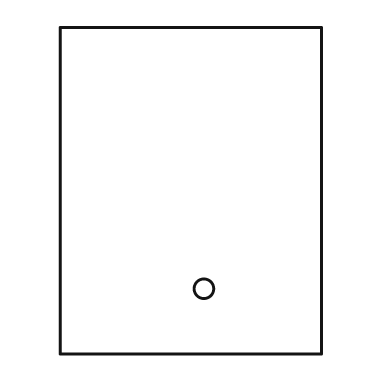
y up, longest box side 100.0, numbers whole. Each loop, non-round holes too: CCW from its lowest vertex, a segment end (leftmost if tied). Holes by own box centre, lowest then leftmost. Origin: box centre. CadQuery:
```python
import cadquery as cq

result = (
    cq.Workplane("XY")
    .moveTo(-40.0, -50.0)
    .lineTo(40.0, -50.0)
    .lineTo(40.0, 50.0)
    .lineTo(-40.0, 50.0)
    .close()
    .moveTo(4.0, -30.0)
    .circle(3.0)
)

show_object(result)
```